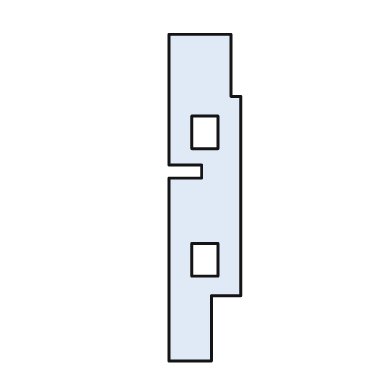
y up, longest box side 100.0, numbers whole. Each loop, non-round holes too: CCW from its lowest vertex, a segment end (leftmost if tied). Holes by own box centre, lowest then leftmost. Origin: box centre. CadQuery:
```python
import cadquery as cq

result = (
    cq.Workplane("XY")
    .moveTo(-11.0, -50.0)
    .lineTo(2.0, -50.0)
    .lineTo(2.0, -30.0)
    .lineTo(11.0, -30.0)
    .lineTo(11.0, 31.0)
    .lineTo(8.0, 31.0)
    .lineTo(8.0, 50.0)
    .lineTo(-11.0, 50.0)
    .lineTo(-11.0, 10.0)
    .lineTo(-1.0, 10.0)
    .lineTo(-1.0, 6.0)
    .lineTo(-11.0, 6.0)
    .close()
    .moveTo(-4.0, -24.0)
    .lineTo(4.0, -24.0)
    .lineTo(4.0, -14.0)
    .lineTo(-4.0, -14.0)
    .close()
    .moveTo(-4.0, 15.0)
    .lineTo(4.0, 15.0)
    .lineTo(4.0, 25.0)
    .lineTo(-4.0, 25.0)
    .close()
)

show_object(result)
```